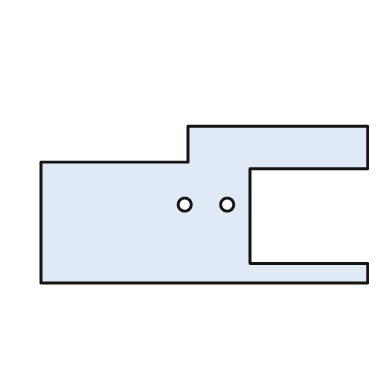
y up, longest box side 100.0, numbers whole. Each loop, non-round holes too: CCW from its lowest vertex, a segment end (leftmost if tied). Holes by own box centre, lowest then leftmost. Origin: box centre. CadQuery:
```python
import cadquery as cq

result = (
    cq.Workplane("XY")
    .moveTo(-50.0, -24.0)
    .lineTo(50.0, -24.0)
    .lineTo(50.0, -18.0)
    .lineTo(14.0, -18.0)
    .lineTo(14.0, 11.0)
    .lineTo(50.0, 11.0)
    .lineTo(50.0, 24.0)
    .lineTo(-5.0, 24.0)
    .lineTo(-5.0, 13.0)
    .lineTo(-50.0, 13.0)
    .close()
    .moveTo(-6.0, 0.0)
    .circle(2.0)
    .moveTo(7.0, 0.0)
    .circle(2.0)
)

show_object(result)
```